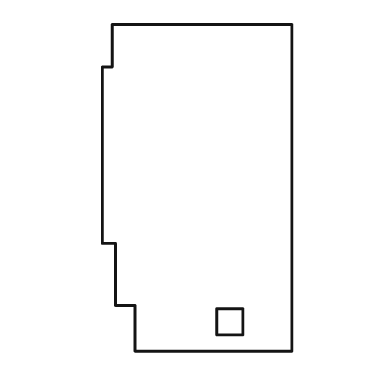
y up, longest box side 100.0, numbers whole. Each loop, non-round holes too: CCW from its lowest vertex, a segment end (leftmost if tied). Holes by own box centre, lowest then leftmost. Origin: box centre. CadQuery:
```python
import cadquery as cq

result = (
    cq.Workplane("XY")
    .moveTo(-19.0, -50.0)
    .lineTo(29.0, -50.0)
    .lineTo(29.0, 50.0)
    .lineTo(-26.0, 50.0)
    .lineTo(-26.0, 37.0)
    .lineTo(-29.0, 37.0)
    .lineTo(-29.0, -17.0)
    .lineTo(-25.0, -17.0)
    .lineTo(-25.0, -36.0)
    .lineTo(-19.0, -36.0)
    .close()
    .moveTo(6.0, -45.0)
    .lineTo(14.0, -45.0)
    .lineTo(14.0, -37.0)
    .lineTo(6.0, -37.0)
    .close()
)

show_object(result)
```